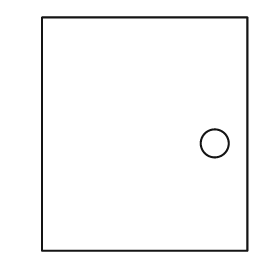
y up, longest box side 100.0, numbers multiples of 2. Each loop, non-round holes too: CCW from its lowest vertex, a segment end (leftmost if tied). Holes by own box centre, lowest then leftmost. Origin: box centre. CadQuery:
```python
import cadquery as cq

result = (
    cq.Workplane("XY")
    .moveTo(-44.0, -50.0)
    .lineTo(44.0, -50.0)
    .lineTo(44.0, 50.0)
    .lineTo(-44.0, 50.0)
    .close()
    .moveTo(30.0, -4.0)
    .circle(6.0)
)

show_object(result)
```